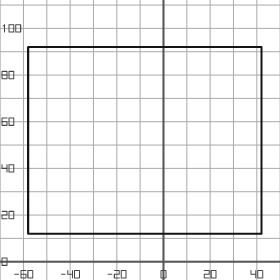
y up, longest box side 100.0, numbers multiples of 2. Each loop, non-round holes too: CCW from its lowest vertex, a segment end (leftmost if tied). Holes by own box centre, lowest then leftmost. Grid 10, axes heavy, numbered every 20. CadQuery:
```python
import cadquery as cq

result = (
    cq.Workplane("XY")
    .moveTo(-58.0, 12.0)
    .lineTo(42.0, 12.0)
    .lineTo(42.0, 92.0)
    .lineTo(-58.0, 92.0)
    .close()
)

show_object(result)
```